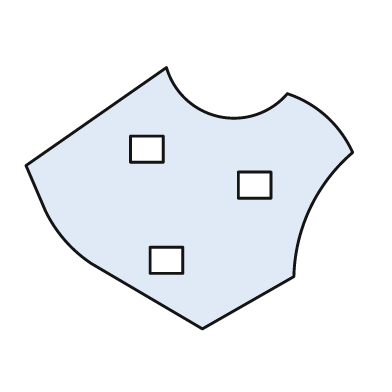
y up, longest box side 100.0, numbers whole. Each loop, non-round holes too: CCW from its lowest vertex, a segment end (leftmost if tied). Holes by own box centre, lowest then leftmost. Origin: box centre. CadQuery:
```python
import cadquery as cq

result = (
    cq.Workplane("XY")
    .moveTo(4.0, -40.0)
    .lineTo(32.0, -24.0)
    .threePointArc((37.0, -3.0), (50.0, 14.0))
    .threePointArc((42.0, 25.0), (30.0, 32.0))
    .threePointArc((9.0, 25.0), (-7.0, 40.0))
    .lineTo(-50.0, 10.0)
    .lineTo(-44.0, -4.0)
    .threePointArc((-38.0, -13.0), (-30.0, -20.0))
    .close()
    .moveTo(-12.0, -23.0)
    .lineTo(-2.0, -23.0)
    .lineTo(-2.0, -15.0)
    .lineTo(-12.0, -15.0)
    .close()
    .moveTo(15.0, 0.0)
    .lineTo(25.0, 0.0)
    .lineTo(25.0, 8.0)
    .lineTo(15.0, 8.0)
    .close()
    .moveTo(-18.0, 11.0)
    .lineTo(-8.0, 11.0)
    .lineTo(-8.0, 19.0)
    .lineTo(-18.0, 19.0)
    .close()
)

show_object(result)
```